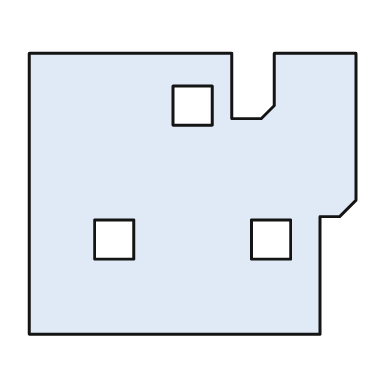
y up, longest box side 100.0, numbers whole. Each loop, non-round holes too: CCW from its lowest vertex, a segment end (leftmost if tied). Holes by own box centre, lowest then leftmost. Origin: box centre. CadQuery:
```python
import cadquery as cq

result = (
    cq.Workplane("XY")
    .moveTo(-50.0, -43.0)
    .lineTo(39.0, -43.0)
    .lineTo(39.0, -7.0)
    .lineTo(45.0, -7.0)
    .lineTo(50.0, -2.0)
    .lineTo(50.0, 43.0)
    .lineTo(25.0, 43.0)
    .lineTo(25.0, 27.0)
    .lineTo(21.0, 23.0)
    .lineTo(12.0, 23.0)
    .lineTo(12.0, 43.0)
    .lineTo(-50.0, 43.0)
    .close()
    .moveTo(-30.0, -20.0)
    .lineTo(-18.0, -20.0)
    .lineTo(-18.0, -8.0)
    .lineTo(-30.0, -8.0)
    .close()
    .moveTo(18.0, -20.0)
    .lineTo(30.0, -20.0)
    .lineTo(30.0, -8.0)
    .lineTo(18.0, -8.0)
    .close()
    .moveTo(-6.0, 21.0)
    .lineTo(6.0, 21.0)
    .lineTo(6.0, 33.0)
    .lineTo(-6.0, 33.0)
    .close()
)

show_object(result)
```